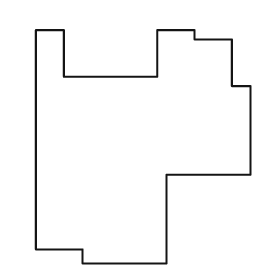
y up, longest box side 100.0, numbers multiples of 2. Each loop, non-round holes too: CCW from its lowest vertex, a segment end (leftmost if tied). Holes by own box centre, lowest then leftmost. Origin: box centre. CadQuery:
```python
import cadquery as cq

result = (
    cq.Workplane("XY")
    .moveTo(-26.0, -50.0)
    .lineTo(10.0, -50.0)
    .lineTo(10.0, -12.0)
    .lineTo(46.0, -12.0)
    .lineTo(46.0, 26.0)
    .lineTo(38.0, 26.0)
    .lineTo(38.0, 46.0)
    .lineTo(22.0, 46.0)
    .lineTo(22.0, 50.0)
    .lineTo(6.0, 50.0)
    .lineTo(6.0, 30.0)
    .lineTo(-34.0, 30.0)
    .lineTo(-34.0, 50.0)
    .lineTo(-46.0, 50.0)
    .lineTo(-46.0, -44.0)
    .lineTo(-26.0, -44.0)
    .close()
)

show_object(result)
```